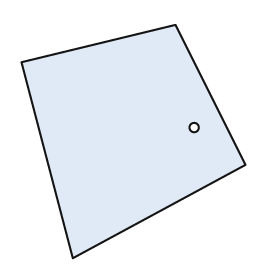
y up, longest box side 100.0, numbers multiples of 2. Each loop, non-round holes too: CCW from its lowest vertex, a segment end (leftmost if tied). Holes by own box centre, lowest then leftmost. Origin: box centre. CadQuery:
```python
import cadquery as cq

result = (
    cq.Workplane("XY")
    .moveTo(-26.0, -50.0)
    .lineTo(48.0, -10.0)
    .lineTo(18.0, 50.0)
    .lineTo(-48.0, 34.0)
    .close()
    .moveTo(26.0, 6.0)
    .circle(2.0)
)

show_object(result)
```